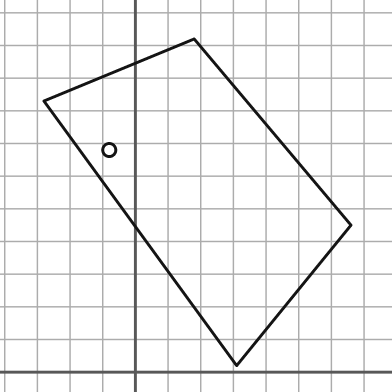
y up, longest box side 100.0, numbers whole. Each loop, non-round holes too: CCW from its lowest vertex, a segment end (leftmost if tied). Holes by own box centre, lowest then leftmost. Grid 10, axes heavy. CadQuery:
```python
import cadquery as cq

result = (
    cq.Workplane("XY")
    .moveTo(31.0, 2.0)
    .lineTo(66.0, 45.0)
    .lineTo(18.0, 102.0)
    .lineTo(-28.0, 83.0)
    .close()
    .moveTo(-8.0, 68.0)
    .circle(2.0)
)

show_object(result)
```